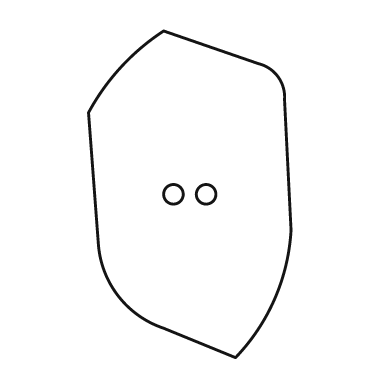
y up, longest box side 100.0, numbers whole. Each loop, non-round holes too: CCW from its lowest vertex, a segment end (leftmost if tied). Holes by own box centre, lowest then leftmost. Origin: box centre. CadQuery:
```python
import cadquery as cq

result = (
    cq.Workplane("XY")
    .moveTo(14.0, -50.0)
    .threePointArc((26.0, -32.0), (31.0, -11.0))
    .lineTo(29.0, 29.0)
    .threePointArc((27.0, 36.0), (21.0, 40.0))
    .lineTo(-8.0, 50.0)
    .threePointArc((-21.0, 39.0), (-31.0, 25.0))
    .lineTo(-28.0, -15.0)
    .threePointArc((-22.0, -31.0), (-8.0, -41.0))
    .close()
    .moveTo(-5.0, 0.0)
    .circle(3.0)
    .moveTo(5.0, 0.0)
    .circle(3.0)
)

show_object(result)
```